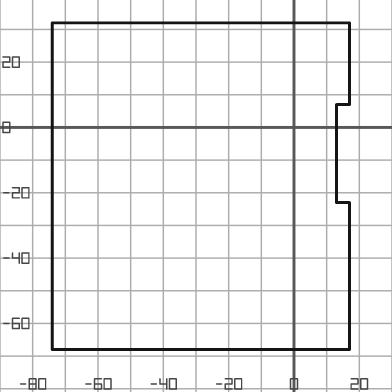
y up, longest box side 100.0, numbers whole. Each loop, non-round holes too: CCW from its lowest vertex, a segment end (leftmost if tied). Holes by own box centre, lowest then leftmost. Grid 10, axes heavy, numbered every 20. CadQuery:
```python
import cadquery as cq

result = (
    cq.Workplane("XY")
    .moveTo(-74.0, -68.0)
    .lineTo(17.0, -68.0)
    .lineTo(17.0, -23.0)
    .lineTo(13.0, -23.0)
    .lineTo(13.0, 7.0)
    .lineTo(17.0, 7.0)
    .lineTo(17.0, 32.0)
    .lineTo(-74.0, 32.0)
    .close()
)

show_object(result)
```